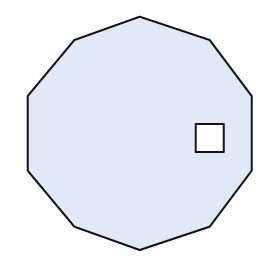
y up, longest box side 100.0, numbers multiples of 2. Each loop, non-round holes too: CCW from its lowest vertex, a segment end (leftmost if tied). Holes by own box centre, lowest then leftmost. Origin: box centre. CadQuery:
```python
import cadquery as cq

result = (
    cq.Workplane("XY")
    .moveTo(0.0, -50.0)
    .lineTo(30.0, -40.0)
    .lineTo(48.0, -16.0)
    .lineTo(48.0, 16.0)
    .lineTo(30.0, 40.0)
    .lineTo(0.0, 50.0)
    .lineTo(-28.0, 40.0)
    .lineTo(-48.0, 16.0)
    .lineTo(-48.0, -16.0)
    .lineTo(-28.0, -40.0)
    .close()
    .moveTo(24.0, -8.0)
    .lineTo(36.0, -8.0)
    .lineTo(36.0, 4.0)
    .lineTo(24.0, 4.0)
    .close()
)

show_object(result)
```